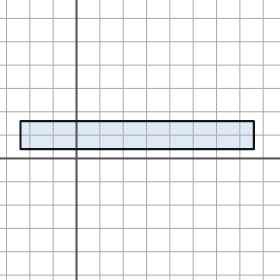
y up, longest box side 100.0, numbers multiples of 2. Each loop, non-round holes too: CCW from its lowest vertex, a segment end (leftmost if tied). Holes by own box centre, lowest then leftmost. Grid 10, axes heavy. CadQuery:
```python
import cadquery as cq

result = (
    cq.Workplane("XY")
    .moveTo(-24.0, 4.0)
    .lineTo(76.0, 4.0)
    .lineTo(76.0, 16.0)
    .lineTo(-24.0, 16.0)
    .close()
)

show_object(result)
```